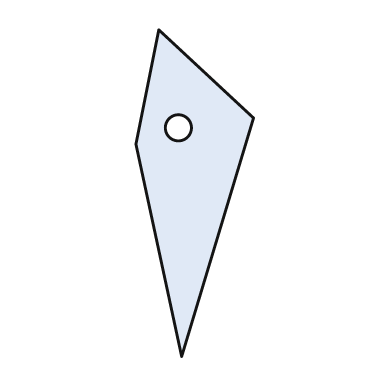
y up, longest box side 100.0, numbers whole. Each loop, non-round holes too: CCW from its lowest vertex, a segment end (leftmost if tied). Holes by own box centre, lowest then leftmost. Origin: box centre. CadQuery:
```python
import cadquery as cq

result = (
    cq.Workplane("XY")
    .moveTo(-4.0, -50.0)
    .lineTo(18.0, 23.0)
    .lineTo(-11.0, 50.0)
    .lineTo(-18.0, 15.0)
    .close()
    .moveTo(-5.0, 20.0)
    .circle(4.0)
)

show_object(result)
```